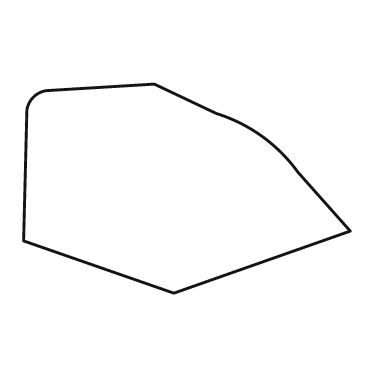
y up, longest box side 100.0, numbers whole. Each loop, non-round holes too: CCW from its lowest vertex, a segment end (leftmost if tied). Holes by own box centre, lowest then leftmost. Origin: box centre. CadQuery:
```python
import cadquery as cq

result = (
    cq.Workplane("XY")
    .moveTo(-4.0, -32.0)
    .lineTo(50.0, -13.0)
    .lineTo(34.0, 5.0)
    .threePointArc((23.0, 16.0), (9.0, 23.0))
    .lineTo(-10.0, 32.0)
    .lineTo(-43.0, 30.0)
    .threePointArc((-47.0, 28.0), (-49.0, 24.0))
    .lineTo(-50.0, -16.0)
    .close()
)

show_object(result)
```